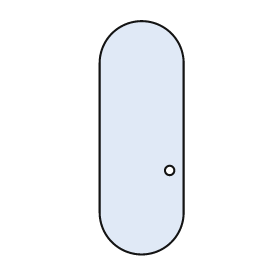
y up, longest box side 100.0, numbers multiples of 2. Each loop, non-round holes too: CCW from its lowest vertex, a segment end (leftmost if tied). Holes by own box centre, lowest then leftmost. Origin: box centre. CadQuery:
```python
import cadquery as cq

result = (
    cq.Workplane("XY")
    .moveTo(-18.0, -32.0)
    .threePointArc((0.0, -50.0), (18.0, -32.0))
    .lineTo(18.0, 32.0)
    .threePointArc((0.0, 50.0), (-18.0, 32.0))
    .close()
    .moveTo(12.0, -14.0)
    .circle(2.0)
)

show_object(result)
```